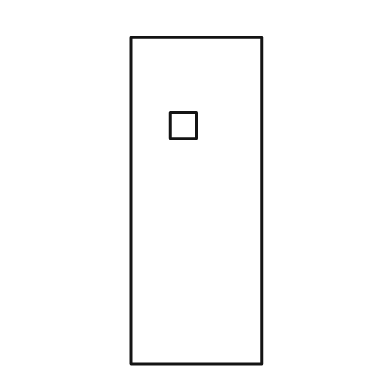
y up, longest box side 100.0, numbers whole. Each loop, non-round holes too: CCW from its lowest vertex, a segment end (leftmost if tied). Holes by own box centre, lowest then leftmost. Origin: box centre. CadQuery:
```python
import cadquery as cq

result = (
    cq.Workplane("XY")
    .moveTo(-20.0, -50.0)
    .lineTo(20.0, -50.0)
    .lineTo(20.0, 50.0)
    .lineTo(-20.0, 50.0)
    .close()
    .moveTo(-8.0, 19.0)
    .lineTo(0.0, 19.0)
    .lineTo(0.0, 27.0)
    .lineTo(-8.0, 27.0)
    .close()
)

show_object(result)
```